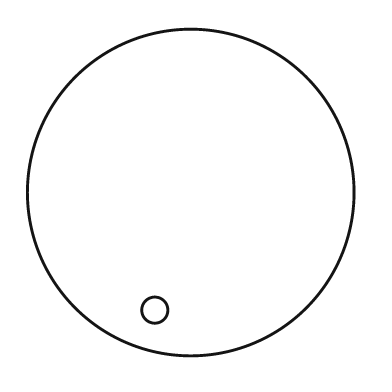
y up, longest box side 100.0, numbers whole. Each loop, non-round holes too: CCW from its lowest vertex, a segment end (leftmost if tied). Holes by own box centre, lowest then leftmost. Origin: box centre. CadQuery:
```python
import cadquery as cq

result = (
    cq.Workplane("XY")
    .moveTo(0.0, 0.0)
    .circle(50.0)
    .moveTo(-11.0, -36.0)
    .circle(4.0)
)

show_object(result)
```